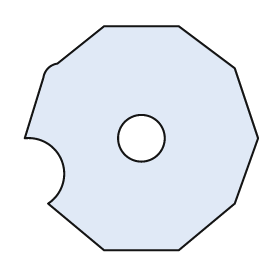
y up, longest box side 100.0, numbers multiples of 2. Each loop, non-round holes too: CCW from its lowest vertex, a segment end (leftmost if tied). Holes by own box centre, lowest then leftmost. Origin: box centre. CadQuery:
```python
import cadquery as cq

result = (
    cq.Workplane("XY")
    .moveTo(-16.0, -48.0)
    .lineTo(16.0, -48.0)
    .lineTo(40.0, -28.0)
    .lineTo(50.0, 0.0)
    .lineTo(40.0, 30.0)
    .lineTo(16.0, 48.0)
    .lineTo(-16.0, 48.0)
    .lineTo(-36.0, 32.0)
    .threePointArc((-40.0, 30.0), (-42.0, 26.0))
    .lineTo(-50.0, 0.0)
    .threePointArc((-34.0, -10.0), (-40.0, -28.0))
    .close()
    .moveTo(0.0, 0.0)
    .circle(10.0)
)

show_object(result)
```